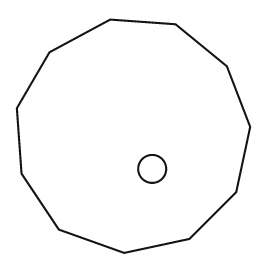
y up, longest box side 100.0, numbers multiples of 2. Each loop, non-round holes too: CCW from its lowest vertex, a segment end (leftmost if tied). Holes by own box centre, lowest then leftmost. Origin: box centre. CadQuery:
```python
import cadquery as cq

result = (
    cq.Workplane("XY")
    .moveTo(-4.0, -50.0)
    .lineTo(24.0, -44.0)
    .lineTo(44.0, -24.0)
    .lineTo(50.0, 4.0)
    .lineTo(40.0, 30.0)
    .lineTo(18.0, 48.0)
    .lineTo(-10.0, 50.0)
    .lineTo(-36.0, 36.0)
    .lineTo(-50.0, 12.0)
    .lineTo(-48.0, -16.0)
    .lineTo(-32.0, -40.0)
    .close()
    .moveTo(8.0, -14.0)
    .circle(6.0)
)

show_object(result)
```